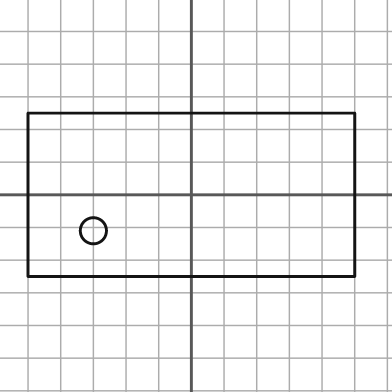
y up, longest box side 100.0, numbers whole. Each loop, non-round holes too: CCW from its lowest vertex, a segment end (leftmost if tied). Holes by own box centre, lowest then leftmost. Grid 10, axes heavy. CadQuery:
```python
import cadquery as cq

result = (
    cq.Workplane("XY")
    .moveTo(-50.0, -25.0)
    .lineTo(50.0, -25.0)
    .lineTo(50.0, 25.0)
    .lineTo(-50.0, 25.0)
    .close()
    .moveTo(-30.0, -11.0)
    .circle(4.0)
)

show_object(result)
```